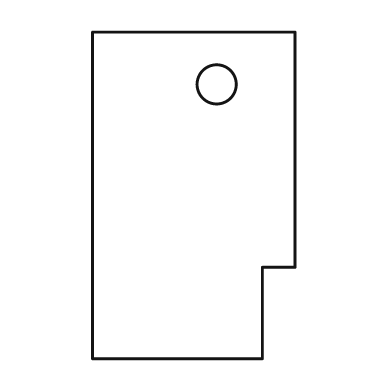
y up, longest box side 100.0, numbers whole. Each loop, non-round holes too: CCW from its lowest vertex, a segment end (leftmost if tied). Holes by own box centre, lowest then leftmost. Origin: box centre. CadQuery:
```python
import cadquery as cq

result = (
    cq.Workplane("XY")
    .moveTo(-31.0, -50.0)
    .lineTo(21.0, -50.0)
    .lineTo(21.0, -22.0)
    .lineTo(31.0, -22.0)
    .lineTo(31.0, 50.0)
    .lineTo(-31.0, 50.0)
    .close()
    .moveTo(7.0, 34.0)
    .circle(6.0)
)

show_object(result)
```